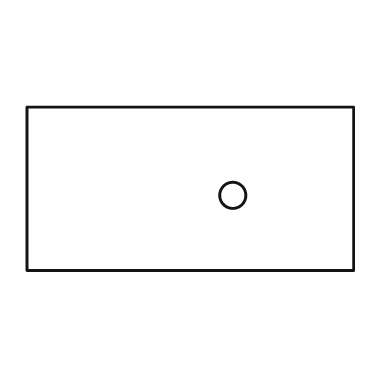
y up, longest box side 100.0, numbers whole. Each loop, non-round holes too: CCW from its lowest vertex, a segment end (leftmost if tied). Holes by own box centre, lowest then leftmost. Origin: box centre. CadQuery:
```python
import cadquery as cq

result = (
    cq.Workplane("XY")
    .moveTo(-50.0, -25.0)
    .lineTo(50.0, -25.0)
    .lineTo(50.0, 25.0)
    .lineTo(-50.0, 25.0)
    .close()
    .moveTo(13.0, -2.0)
    .circle(4.0)
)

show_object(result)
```